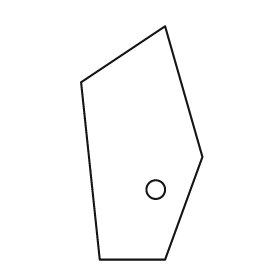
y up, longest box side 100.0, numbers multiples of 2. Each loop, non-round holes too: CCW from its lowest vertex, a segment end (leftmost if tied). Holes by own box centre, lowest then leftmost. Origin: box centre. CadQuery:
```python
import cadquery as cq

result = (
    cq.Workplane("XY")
    .moveTo(-18.0, -50.0)
    .lineTo(10.0, -50.0)
    .lineTo(26.0, -6.0)
    .lineTo(10.0, 50.0)
    .lineTo(-26.0, 26.0)
    .close()
    .moveTo(6.0, -20.0)
    .circle(4.0)
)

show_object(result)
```